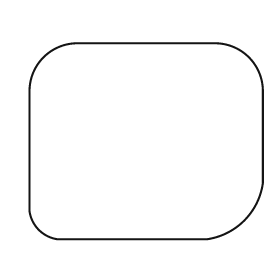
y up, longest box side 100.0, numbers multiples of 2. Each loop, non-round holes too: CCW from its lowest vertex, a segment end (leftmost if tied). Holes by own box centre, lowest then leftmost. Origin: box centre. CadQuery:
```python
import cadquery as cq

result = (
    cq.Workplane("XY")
    .moveTo(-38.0, -42.0)
    .lineTo(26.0, -42.0)
    .threePointArc((42.0, -34.0), (50.0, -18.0))
    .lineTo(50.0, 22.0)
    .threePointArc((44.0, 36.0), (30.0, 42.0))
    .lineTo(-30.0, 42.0)
    .threePointArc((-44.0, 36.0), (-50.0, 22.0))
    .lineTo(-50.0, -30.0)
    .threePointArc((-46.0, -38.0), (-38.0, -42.0))
    .close()
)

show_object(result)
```